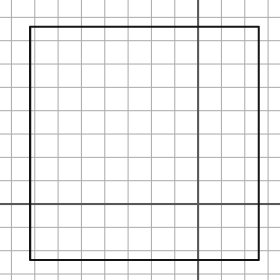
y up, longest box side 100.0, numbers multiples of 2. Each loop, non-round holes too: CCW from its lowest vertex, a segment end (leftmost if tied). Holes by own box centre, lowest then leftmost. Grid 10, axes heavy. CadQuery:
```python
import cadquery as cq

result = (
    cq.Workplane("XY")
    .moveTo(-72.0, -24.0)
    .lineTo(26.0, -24.0)
    .lineTo(26.0, 76.0)
    .lineTo(-72.0, 76.0)
    .close()
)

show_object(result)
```